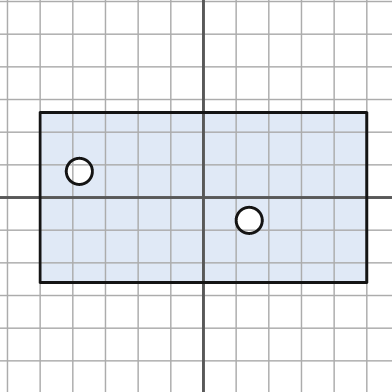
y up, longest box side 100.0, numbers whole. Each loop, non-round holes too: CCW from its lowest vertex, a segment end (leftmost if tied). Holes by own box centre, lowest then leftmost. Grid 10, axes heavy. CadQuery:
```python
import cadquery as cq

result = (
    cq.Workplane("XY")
    .moveTo(-50.0, -26.0)
    .lineTo(50.0, -26.0)
    .lineTo(50.0, 26.0)
    .lineTo(-50.0, 26.0)
    .close()
    .moveTo(14.0, -7.0)
    .circle(4.0)
    .moveTo(-38.0, 8.0)
    .circle(4.0)
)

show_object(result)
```